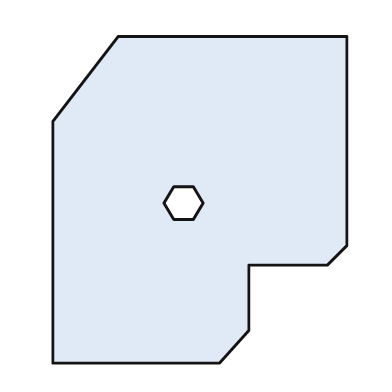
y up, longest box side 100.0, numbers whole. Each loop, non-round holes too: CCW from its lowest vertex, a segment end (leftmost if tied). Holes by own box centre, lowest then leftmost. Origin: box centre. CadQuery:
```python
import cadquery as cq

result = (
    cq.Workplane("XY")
    .moveTo(-45.0, -50.0)
    .lineTo(6.0, -50.0)
    .lineTo(15.0, -40.0)
    .lineTo(15.0, -20.0)
    .lineTo(39.0, -20.0)
    .lineTo(45.0, -14.0)
    .lineTo(45.0, 50.0)
    .lineTo(-25.0, 50.0)
    .lineTo(-45.0, 24.0)
    .close()
    .moveTo(-8.0, -6.0)
    .lineTo(-2.0, -6.0)
    .lineTo(1.0, -1.0)
    .lineTo(-2.0, 4.0)
    .lineTo(-8.0, 4.0)
    .lineTo(-11.0, -1.0)
    .close()
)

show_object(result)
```